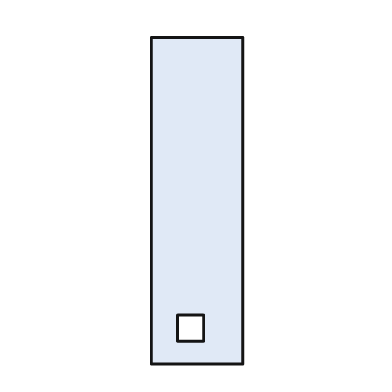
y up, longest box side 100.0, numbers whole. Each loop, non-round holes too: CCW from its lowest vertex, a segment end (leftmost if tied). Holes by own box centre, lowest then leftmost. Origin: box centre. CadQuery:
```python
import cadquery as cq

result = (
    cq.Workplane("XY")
    .moveTo(-14.0, -50.0)
    .lineTo(14.0, -50.0)
    .lineTo(14.0, 50.0)
    .lineTo(-14.0, 50.0)
    .close()
    .moveTo(-6.0, -43.0)
    .lineTo(2.0, -43.0)
    .lineTo(2.0, -35.0)
    .lineTo(-6.0, -35.0)
    .close()
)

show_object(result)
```